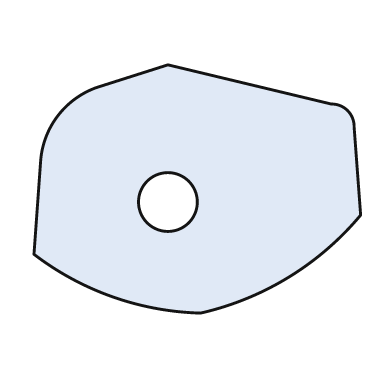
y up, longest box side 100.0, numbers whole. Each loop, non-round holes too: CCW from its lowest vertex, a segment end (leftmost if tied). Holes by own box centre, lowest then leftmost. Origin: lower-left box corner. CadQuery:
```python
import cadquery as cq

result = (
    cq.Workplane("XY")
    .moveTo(51.0, 0.0)
    .threePointArc((78.0, 11.0), (100.0, 30.0))
    .lineTo(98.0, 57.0)
    .threePointArc((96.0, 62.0), (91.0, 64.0))
    .lineTo(41.0, 76.0)
    .lineTo(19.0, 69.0)
    .threePointArc((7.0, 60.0), (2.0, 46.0))
    .lineTo(0.0, 18.0)
    .threePointArc((24.0, 5.0), (51.0, 0.0))
    .close()
    .moveTo(41.0, 34.0)
    .circle(9.0)
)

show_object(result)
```